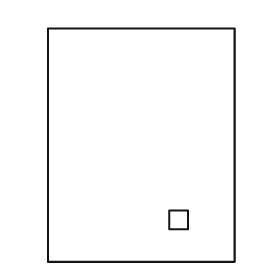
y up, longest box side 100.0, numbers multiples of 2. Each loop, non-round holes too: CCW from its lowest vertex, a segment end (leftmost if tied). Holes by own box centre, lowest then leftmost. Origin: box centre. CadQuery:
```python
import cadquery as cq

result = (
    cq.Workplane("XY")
    .moveTo(-40.0, -50.0)
    .lineTo(40.0, -50.0)
    .lineTo(40.0, 50.0)
    .lineTo(-40.0, 50.0)
    .close()
    .moveTo(12.0, -36.0)
    .lineTo(20.0, -36.0)
    .lineTo(20.0, -28.0)
    .lineTo(12.0, -28.0)
    .close()
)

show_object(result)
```